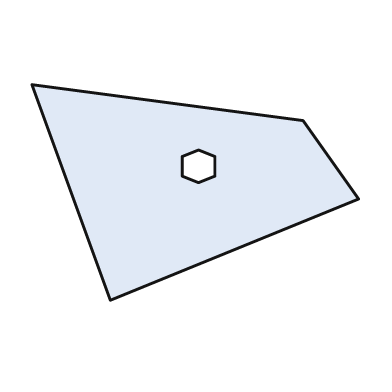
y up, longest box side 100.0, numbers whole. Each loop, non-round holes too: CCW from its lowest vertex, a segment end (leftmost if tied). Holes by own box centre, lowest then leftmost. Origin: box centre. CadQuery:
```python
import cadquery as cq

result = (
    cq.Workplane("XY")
    .moveTo(-26.0, -33.0)
    .lineTo(50.0, -2.0)
    .lineTo(33.0, 22.0)
    .lineTo(-50.0, 33.0)
    .close()
    .moveTo(1.0, 3.0)
    .lineTo(6.0, 5.0)
    .lineTo(6.0, 11.0)
    .lineTo(1.0, 13.0)
    .lineTo(-4.0, 11.0)
    .lineTo(-4.0, 5.0)
    .close()
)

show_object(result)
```